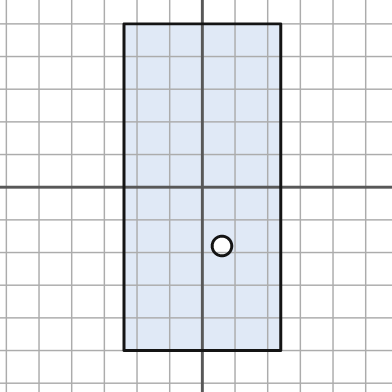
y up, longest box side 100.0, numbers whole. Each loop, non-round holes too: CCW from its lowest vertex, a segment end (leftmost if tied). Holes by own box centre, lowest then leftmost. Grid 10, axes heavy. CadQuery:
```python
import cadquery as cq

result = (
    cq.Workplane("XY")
    .moveTo(-24.0, -50.0)
    .lineTo(24.0, -50.0)
    .lineTo(24.0, 50.0)
    .lineTo(-24.0, 50.0)
    .close()
    .moveTo(6.0, -18.0)
    .circle(3.0)
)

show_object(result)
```